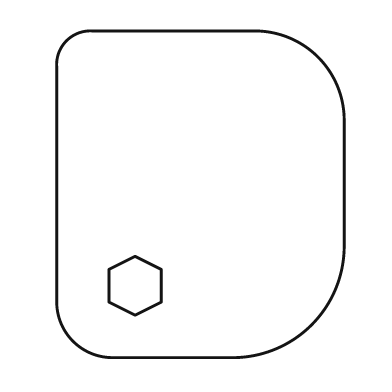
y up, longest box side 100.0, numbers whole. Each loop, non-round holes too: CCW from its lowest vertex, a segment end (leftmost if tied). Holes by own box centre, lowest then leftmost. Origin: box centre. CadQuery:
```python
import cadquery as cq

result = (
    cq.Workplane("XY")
    .moveTo(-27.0, -50.0)
    .lineTo(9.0, -50.0)
    .threePointArc((34.0, -40.0), (44.0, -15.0))
    .lineTo(44.0, 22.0)
    .threePointArc((36.0, 42.0), (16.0, 50.0))
    .lineTo(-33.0, 50.0)
    .threePointArc((-41.0, 47.0), (-44.0, 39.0))
    .lineTo(-44.0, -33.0)
    .threePointArc((-39.0, -45.0), (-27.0, -50.0))
    .close()
    .moveTo(-20.0, -37.0)
    .lineTo(-12.0, -33.0)
    .lineTo(-12.0, -23.0)
    .lineTo(-20.0, -19.0)
    .lineTo(-28.0, -23.0)
    .lineTo(-28.0, -33.0)
    .close()
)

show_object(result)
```